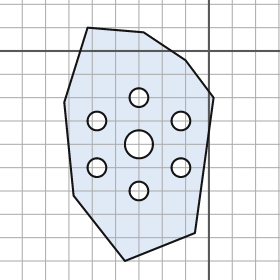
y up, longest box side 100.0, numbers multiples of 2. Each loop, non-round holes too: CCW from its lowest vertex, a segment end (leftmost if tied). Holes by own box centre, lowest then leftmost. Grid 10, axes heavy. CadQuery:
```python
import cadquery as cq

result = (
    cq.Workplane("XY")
    .moveTo(-36.0, -90.0)
    .lineTo(-6.0, -78.0)
    .lineTo(2.0, -20.0)
    .lineTo(-10.0, -4.0)
    .lineTo(-28.0, 8.0)
    .lineTo(-52.0, 10.0)
    .lineTo(-62.0, -22.0)
    .lineTo(-58.0, -62.0)
    .close()
    .moveTo(-30.0, -60.0)
    .circle(4.0)
    .moveTo(-48.0, -50.0)
    .circle(4.0)
    .moveTo(-12.0, -50.0)
    .circle(4.0)
    .moveTo(-30.0, -40.0)
    .circle(6.0)
    .moveTo(-48.0, -30.0)
    .circle(4.0)
    .moveTo(-12.0, -30.0)
    .circle(4.0)
    .moveTo(-30.0, -20.0)
    .circle(4.0)
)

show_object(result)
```